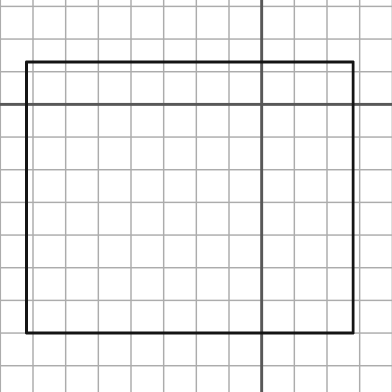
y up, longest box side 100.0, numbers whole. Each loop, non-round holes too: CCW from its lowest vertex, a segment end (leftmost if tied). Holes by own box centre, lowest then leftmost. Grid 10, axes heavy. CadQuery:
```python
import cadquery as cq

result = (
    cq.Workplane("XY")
    .moveTo(-72.0, -70.0)
    .lineTo(28.0, -70.0)
    .lineTo(28.0, 13.0)
    .lineTo(-72.0, 13.0)
    .close()
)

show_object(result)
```